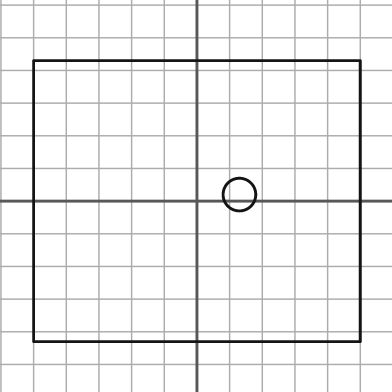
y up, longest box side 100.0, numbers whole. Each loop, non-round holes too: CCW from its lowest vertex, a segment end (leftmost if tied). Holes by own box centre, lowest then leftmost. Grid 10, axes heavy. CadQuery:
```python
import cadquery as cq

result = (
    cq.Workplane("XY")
    .moveTo(-50.0, -43.0)
    .lineTo(50.0, -43.0)
    .lineTo(50.0, 43.0)
    .lineTo(-50.0, 43.0)
    .close()
    .moveTo(13.0, 2.0)
    .circle(5.0)
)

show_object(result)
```